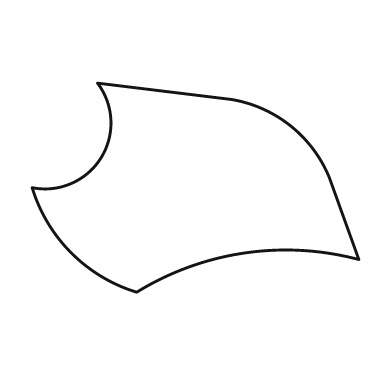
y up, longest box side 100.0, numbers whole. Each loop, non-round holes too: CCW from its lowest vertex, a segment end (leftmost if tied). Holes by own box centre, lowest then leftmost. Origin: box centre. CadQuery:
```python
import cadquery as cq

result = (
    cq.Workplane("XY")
    .moveTo(-18.0, -32.0)
    .threePointArc((15.0, -20.0), (50.0, -22.0))
    .lineTo(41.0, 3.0)
    .threePointArc((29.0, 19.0), (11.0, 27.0))
    .lineTo(-30.0, 32.0)
    .threePointArc((-29.0, 9.0), (-50.0, 0.0))
    .threePointArc((-38.0, -20.0), (-18.0, -32.0))
    .close()
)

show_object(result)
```